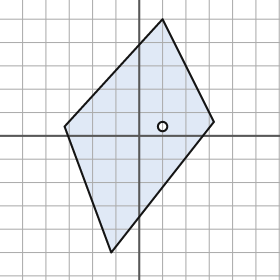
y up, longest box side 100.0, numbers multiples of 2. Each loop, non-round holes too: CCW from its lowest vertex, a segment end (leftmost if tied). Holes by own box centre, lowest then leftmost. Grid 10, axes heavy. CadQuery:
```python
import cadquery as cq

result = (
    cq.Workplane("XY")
    .moveTo(-12.0, -50.0)
    .lineTo(32.0, 6.0)
    .lineTo(10.0, 50.0)
    .lineTo(-32.0, 4.0)
    .close()
    .moveTo(10.0, 4.0)
    .circle(2.0)
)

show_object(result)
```